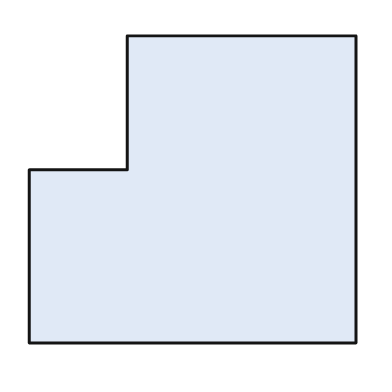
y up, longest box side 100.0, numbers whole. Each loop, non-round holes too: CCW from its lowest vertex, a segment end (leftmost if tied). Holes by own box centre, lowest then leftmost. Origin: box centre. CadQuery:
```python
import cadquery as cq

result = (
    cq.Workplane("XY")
    .moveTo(-50.0, -47.0)
    .lineTo(50.0, -47.0)
    .lineTo(50.0, 47.0)
    .lineTo(-20.0, 47.0)
    .lineTo(-20.0, 6.0)
    .lineTo(-50.0, 6.0)
    .close()
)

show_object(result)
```